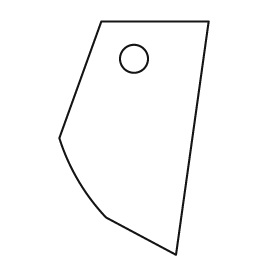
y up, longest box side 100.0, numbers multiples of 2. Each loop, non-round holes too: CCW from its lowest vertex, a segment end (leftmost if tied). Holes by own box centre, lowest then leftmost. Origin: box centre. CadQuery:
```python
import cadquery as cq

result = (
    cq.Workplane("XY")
    .moveTo(18.0, -50.0)
    .lineTo(32.0, 50.0)
    .lineTo(-14.0, 50.0)
    .lineTo(-32.0, 0.0)
    .threePointArc((-24.0, -18.0), (-12.0, -34.0))
    .close()
    .moveTo(0.0, 34.0)
    .circle(6.0)
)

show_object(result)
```